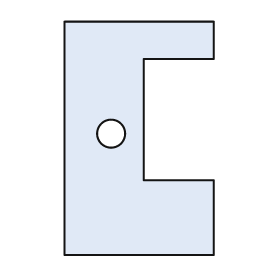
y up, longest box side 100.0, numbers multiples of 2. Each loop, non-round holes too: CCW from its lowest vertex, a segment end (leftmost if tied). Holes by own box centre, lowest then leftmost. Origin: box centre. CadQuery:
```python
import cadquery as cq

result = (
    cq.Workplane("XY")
    .moveTo(-32.0, -50.0)
    .lineTo(32.0, -50.0)
    .lineTo(32.0, -18.0)
    .lineTo(2.0, -18.0)
    .lineTo(2.0, 34.0)
    .lineTo(32.0, 34.0)
    .lineTo(32.0, 50.0)
    .lineTo(-32.0, 50.0)
    .close()
    .moveTo(-12.0, 2.0)
    .circle(6.0)
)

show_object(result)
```